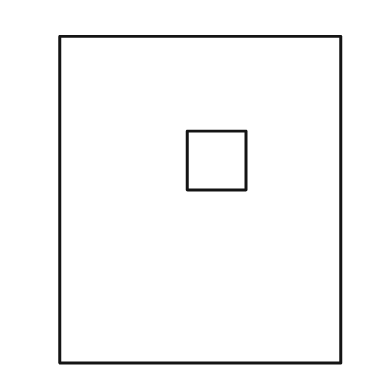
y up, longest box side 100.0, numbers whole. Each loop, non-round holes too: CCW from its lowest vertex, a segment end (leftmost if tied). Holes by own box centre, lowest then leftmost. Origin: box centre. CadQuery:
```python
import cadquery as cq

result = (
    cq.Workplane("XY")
    .moveTo(-43.0, -50.0)
    .lineTo(43.0, -50.0)
    .lineTo(43.0, 50.0)
    .lineTo(-43.0, 50.0)
    .close()
    .moveTo(-4.0, 3.0)
    .lineTo(14.0, 3.0)
    .lineTo(14.0, 21.0)
    .lineTo(-4.0, 21.0)
    .close()
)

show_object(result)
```